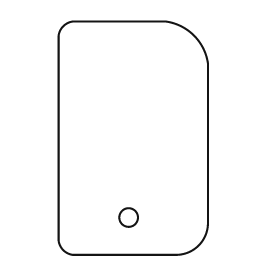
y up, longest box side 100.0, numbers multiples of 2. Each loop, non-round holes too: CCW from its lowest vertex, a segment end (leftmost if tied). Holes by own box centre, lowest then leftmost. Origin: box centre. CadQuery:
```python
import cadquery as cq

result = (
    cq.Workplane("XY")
    .moveTo(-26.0, -50.0)
    .lineTo(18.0, -50.0)
    .threePointArc((28.0, -46.0), (32.0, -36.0))
    .lineTo(32.0, 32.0)
    .threePointArc((26.0, 44.0), (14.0, 50.0))
    .lineTo(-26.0, 50.0)
    .threePointArc((-30.0, 48.0), (-32.0, 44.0))
    .lineTo(-32.0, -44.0)
    .threePointArc((-30.0, -48.0), (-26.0, -50.0))
    .close()
    .moveTo(-2.0, -34.0)
    .circle(4.0)
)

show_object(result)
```